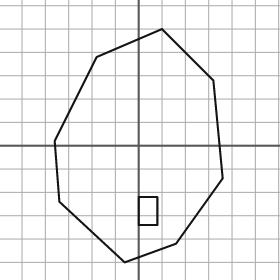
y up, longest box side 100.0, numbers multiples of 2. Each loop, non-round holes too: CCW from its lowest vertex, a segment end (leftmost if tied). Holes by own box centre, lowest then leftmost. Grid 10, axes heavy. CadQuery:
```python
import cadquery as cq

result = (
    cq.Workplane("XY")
    .moveTo(-6.0, -50.0)
    .lineTo(16.0, -42.0)
    .lineTo(36.0, -14.0)
    .lineTo(32.0, 28.0)
    .lineTo(10.0, 50.0)
    .lineTo(-18.0, 38.0)
    .lineTo(-36.0, 2.0)
    .lineTo(-34.0, -24.0)
    .close()
    .moveTo(0.0, -34.0)
    .lineTo(8.0, -34.0)
    .lineTo(8.0, -22.0)
    .lineTo(0.0, -22.0)
    .close()
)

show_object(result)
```